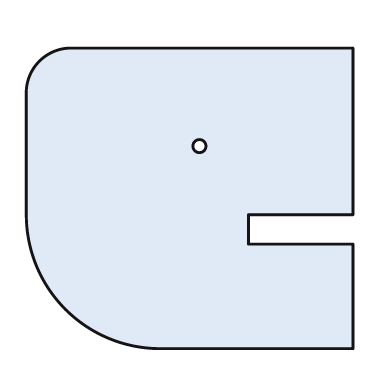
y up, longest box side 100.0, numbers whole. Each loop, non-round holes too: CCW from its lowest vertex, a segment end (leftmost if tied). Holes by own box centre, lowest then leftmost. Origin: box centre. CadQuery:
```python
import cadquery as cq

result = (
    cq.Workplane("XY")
    .moveTo(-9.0, -46.0)
    .lineTo(50.0, -46.0)
    .lineTo(50.0, -14.0)
    .lineTo(18.0, -14.0)
    .lineTo(18.0, -5.0)
    .lineTo(50.0, -5.0)
    .lineTo(50.0, 46.0)
    .lineTo(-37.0, 46.0)
    .threePointArc((-46.0, 42.0), (-50.0, 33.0))
    .lineTo(-50.0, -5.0)
    .threePointArc((-38.0, -34.0), (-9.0, -46.0))
    .close()
    .moveTo(3.0, 16.0)
    .circle(2.0)
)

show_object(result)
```